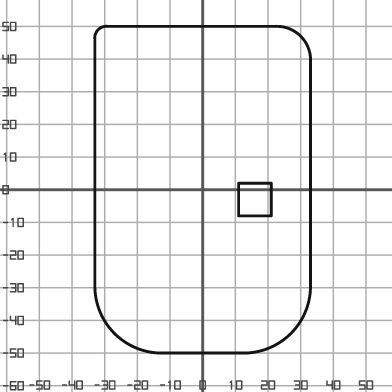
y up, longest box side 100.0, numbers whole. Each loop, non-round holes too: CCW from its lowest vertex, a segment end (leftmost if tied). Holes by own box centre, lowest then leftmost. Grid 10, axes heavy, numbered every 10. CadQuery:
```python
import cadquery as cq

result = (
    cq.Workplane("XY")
    .moveTo(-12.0, -50.0)
    .lineTo(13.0, -50.0)
    .threePointArc((27.0, -44.0), (33.0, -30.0))
    .lineTo(33.0, 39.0)
    .threePointArc((30.0, 47.0), (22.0, 50.0))
    .lineTo(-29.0, 50.0)
    .threePointArc((-32.0, 49.0), (-33.0, 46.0))
    .lineTo(-33.0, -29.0)
    .threePointArc((-27.0, -44.0), (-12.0, -50.0))
    .close()
    .moveTo(11.0, -8.0)
    .lineTo(21.0, -8.0)
    .lineTo(21.0, 2.0)
    .lineTo(11.0, 2.0)
    .close()
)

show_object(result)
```